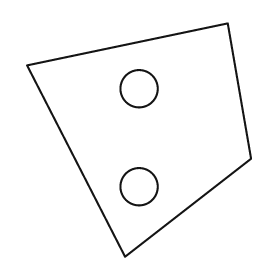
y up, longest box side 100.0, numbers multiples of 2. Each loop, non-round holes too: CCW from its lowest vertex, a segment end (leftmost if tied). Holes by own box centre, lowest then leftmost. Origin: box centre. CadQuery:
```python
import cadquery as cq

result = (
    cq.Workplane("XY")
    .moveTo(-6.0, -50.0)
    .lineTo(48.0, -8.0)
    .lineTo(38.0, 50.0)
    .lineTo(-48.0, 32.0)
    .close()
    .moveTo(0.0, -20.0)
    .circle(8.0)
    .moveTo(0.0, 22.0)
    .circle(8.0)
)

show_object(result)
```